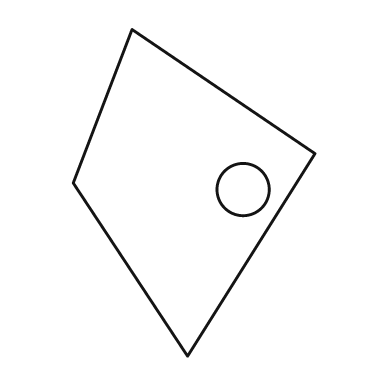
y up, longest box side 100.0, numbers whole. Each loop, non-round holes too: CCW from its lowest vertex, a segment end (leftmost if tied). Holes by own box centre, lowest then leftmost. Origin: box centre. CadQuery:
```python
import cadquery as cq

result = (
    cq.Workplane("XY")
    .moveTo(-2.0, -50.0)
    .lineTo(37.0, 12.0)
    .lineTo(-19.0, 50.0)
    .lineTo(-37.0, 3.0)
    .close()
    .moveTo(15.0, 1.0)
    .circle(8.0)
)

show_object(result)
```